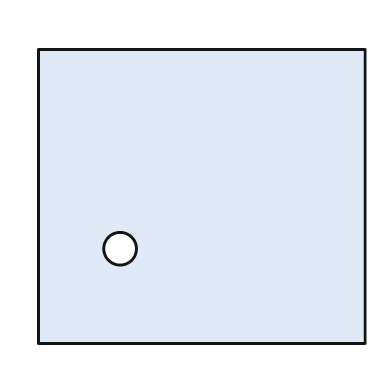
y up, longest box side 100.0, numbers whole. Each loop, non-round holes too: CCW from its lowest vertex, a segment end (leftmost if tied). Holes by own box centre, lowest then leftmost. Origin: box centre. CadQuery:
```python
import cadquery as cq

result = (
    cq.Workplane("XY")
    .moveTo(-50.0, -45.0)
    .lineTo(50.0, -45.0)
    .lineTo(50.0, 45.0)
    .lineTo(-50.0, 45.0)
    .close()
    .moveTo(-25.0, -16.0)
    .circle(5.0)
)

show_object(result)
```